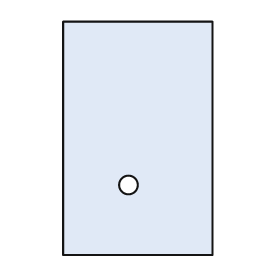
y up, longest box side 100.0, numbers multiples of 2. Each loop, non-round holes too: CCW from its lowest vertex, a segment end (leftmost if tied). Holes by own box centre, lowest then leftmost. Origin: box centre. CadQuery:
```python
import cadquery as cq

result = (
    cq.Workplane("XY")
    .moveTo(-32.0, -50.0)
    .lineTo(32.0, -50.0)
    .lineTo(32.0, 50.0)
    .lineTo(-32.0, 50.0)
    .close()
    .moveTo(-4.0, -20.0)
    .circle(4.0)
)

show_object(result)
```